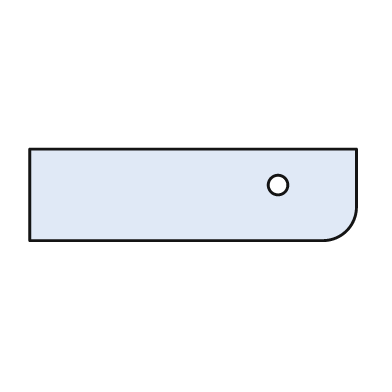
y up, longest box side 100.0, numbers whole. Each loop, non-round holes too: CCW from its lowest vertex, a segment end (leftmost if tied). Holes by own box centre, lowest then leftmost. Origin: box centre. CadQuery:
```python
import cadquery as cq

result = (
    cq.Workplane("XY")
    .moveTo(-50.0, -14.0)
    .lineTo(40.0, -14.0)
    .threePointArc((47.0, -11.0), (50.0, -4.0))
    .lineTo(50.0, 14.0)
    .lineTo(-50.0, 14.0)
    .close()
    .moveTo(26.0, 3.0)
    .circle(3.0)
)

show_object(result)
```